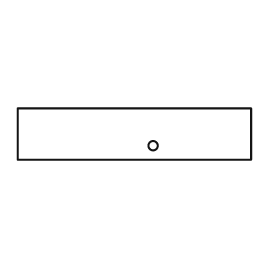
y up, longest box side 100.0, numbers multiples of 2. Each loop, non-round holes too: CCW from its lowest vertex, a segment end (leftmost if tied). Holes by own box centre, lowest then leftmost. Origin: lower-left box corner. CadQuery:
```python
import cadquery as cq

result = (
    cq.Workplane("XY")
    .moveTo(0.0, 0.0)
    .lineTo(100.0, 0.0)
    .lineTo(100.0, 22.0)
    .lineTo(0.0, 22.0)
    .close()
    .moveTo(58.0, 6.0)
    .circle(2.0)
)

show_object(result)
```